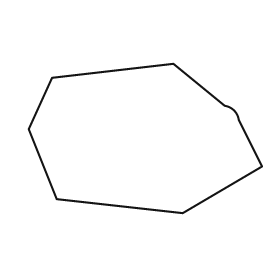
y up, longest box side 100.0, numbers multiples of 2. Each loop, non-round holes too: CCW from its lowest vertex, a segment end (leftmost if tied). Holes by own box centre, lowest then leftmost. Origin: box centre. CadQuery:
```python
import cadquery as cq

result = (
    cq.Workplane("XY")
    .moveTo(16.0, -32.0)
    .lineTo(50.0, -12.0)
    .lineTo(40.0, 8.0)
    .threePointArc((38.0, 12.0), (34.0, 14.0))
    .lineTo(12.0, 32.0)
    .lineTo(-40.0, 26.0)
    .lineTo(-50.0, 4.0)
    .lineTo(-38.0, -26.0)
    .close()
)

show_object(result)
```